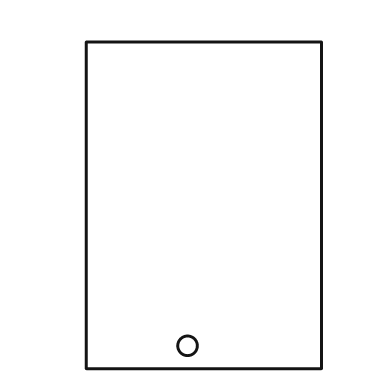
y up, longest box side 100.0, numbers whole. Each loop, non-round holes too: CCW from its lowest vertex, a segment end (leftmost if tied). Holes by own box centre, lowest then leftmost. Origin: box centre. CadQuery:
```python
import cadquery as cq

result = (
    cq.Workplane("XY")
    .moveTo(-36.0, -50.0)
    .lineTo(36.0, -50.0)
    .lineTo(36.0, 50.0)
    .lineTo(-36.0, 50.0)
    .close()
    .moveTo(-5.0, -43.0)
    .circle(3.0)
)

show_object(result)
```